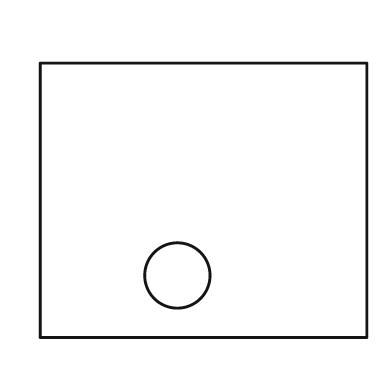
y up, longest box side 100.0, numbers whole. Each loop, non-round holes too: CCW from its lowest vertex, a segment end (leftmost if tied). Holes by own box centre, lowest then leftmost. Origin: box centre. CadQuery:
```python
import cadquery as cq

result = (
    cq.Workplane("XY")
    .moveTo(-50.0, -42.0)
    .lineTo(50.0, -42.0)
    .lineTo(50.0, 42.0)
    .lineTo(-50.0, 42.0)
    .close()
    .moveTo(-8.0, -23.0)
    .circle(10.0)
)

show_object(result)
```